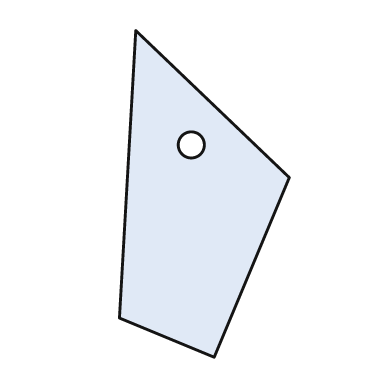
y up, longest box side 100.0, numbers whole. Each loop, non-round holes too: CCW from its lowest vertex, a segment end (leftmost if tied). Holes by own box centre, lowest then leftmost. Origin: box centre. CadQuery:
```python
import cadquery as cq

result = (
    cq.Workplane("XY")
    .moveTo(3.0, -50.0)
    .lineTo(26.0, 5.0)
    .lineTo(-21.0, 50.0)
    .lineTo(-26.0, -38.0)
    .close()
    .moveTo(-4.0, 15.0)
    .circle(4.0)
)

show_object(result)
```